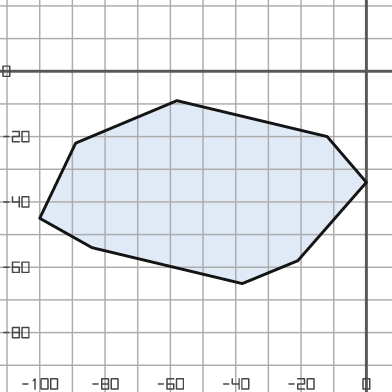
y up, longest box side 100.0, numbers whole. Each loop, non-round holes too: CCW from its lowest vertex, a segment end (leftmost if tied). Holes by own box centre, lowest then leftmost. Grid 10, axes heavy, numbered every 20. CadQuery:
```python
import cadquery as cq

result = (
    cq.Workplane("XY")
    .moveTo(-38.0, -65.0)
    .lineTo(-21.0, -58.0)
    .lineTo(0.0, -34.0)
    .lineTo(-12.0, -20.0)
    .lineTo(-58.0, -9.0)
    .lineTo(-89.0, -22.0)
    .lineTo(-100.0, -45.0)
    .lineTo(-84.0, -54.0)
    .close()
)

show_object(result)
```